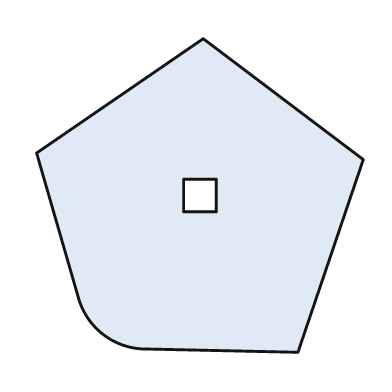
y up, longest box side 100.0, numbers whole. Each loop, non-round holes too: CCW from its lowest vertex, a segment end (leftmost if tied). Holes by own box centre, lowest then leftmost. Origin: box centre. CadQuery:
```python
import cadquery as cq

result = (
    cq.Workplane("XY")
    .moveTo(30.0, -48.0)
    .lineTo(50.0, 11.0)
    .lineTo(1.0, 48.0)
    .lineTo(-50.0, 13.0)
    .lineTo(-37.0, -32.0)
    .threePointArc((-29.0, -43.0), (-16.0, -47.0))
    .close()
    .moveTo(-5.0, -5.0)
    .lineTo(5.0, -5.0)
    .lineTo(5.0, 5.0)
    .lineTo(-5.0, 5.0)
    .close()
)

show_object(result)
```